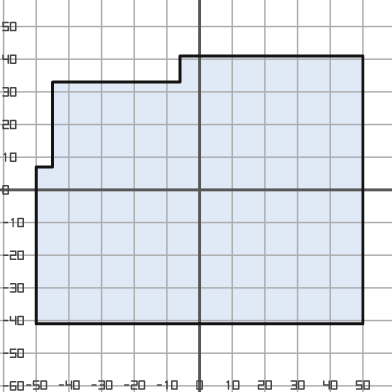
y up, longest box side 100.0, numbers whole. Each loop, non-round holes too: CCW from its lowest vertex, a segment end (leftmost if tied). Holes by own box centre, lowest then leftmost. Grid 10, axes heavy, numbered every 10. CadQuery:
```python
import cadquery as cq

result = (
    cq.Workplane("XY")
    .moveTo(-50.0, -41.0)
    .lineTo(50.0, -41.0)
    .lineTo(50.0, 41.0)
    .lineTo(-6.0, 41.0)
    .lineTo(-6.0, 33.0)
    .lineTo(-45.0, 33.0)
    .lineTo(-45.0, 7.0)
    .lineTo(-50.0, 7.0)
    .close()
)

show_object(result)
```